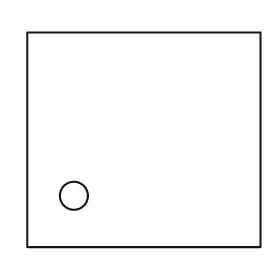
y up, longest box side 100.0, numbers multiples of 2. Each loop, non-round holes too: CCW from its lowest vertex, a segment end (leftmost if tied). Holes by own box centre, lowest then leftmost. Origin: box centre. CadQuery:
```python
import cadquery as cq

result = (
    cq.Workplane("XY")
    .moveTo(-50.0, -46.0)
    .lineTo(50.0, -46.0)
    .lineTo(50.0, 46.0)
    .lineTo(-50.0, 46.0)
    .close()
    .moveTo(-30.0, -24.0)
    .circle(6.0)
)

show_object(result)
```